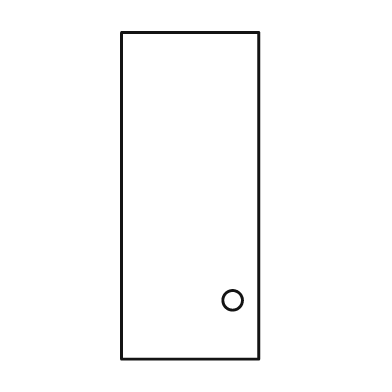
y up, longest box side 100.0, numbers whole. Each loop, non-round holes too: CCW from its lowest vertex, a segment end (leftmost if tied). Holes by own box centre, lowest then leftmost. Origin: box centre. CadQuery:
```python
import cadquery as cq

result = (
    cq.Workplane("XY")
    .moveTo(-21.0, -50.0)
    .lineTo(21.0, -50.0)
    .lineTo(21.0, 50.0)
    .lineTo(-21.0, 50.0)
    .close()
    .moveTo(13.0, -32.0)
    .circle(3.0)
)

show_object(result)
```